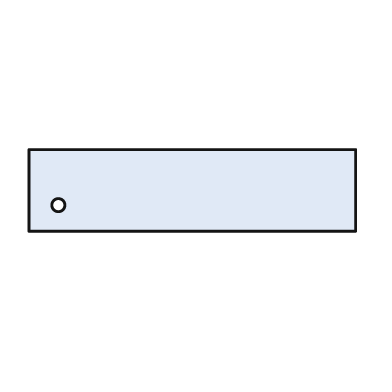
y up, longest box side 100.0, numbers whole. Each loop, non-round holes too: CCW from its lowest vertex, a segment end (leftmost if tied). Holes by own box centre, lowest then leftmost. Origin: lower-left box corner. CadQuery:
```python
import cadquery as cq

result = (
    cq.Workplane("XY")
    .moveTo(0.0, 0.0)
    .lineTo(100.0, 0.0)
    .lineTo(100.0, 25.0)
    .lineTo(0.0, 25.0)
    .close()
    .moveTo(9.0, 8.0)
    .circle(2.0)
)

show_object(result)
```